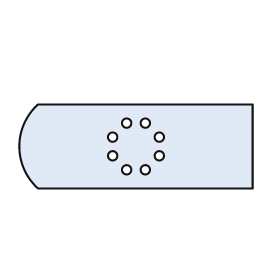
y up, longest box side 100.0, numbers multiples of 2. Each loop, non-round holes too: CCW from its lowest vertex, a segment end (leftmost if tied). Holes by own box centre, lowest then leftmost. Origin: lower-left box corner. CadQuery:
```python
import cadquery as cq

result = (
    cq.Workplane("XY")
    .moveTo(8.0, 0.0)
    .lineTo(100.0, 0.0)
    .lineTo(100.0, 36.0)
    .lineTo(8.0, 36.0)
    .threePointArc((0.0, 18.0), (8.0, 0.0))
    .close()
    .moveTo(46.0, 8.0)
    .circle(2.0)
    .moveTo(54.0, 8.0)
    .circle(2.0)
    .moveTo(40.0, 14.0)
    .circle(2.0)
    .moveTo(60.0, 14.0)
    .circle(2.0)
    .moveTo(40.0, 22.0)
    .circle(2.0)
    .moveTo(60.0, 22.0)
    .circle(2.0)
    .moveTo(46.0, 28.0)
    .circle(2.0)
    .moveTo(54.0, 28.0)
    .circle(2.0)
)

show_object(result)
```